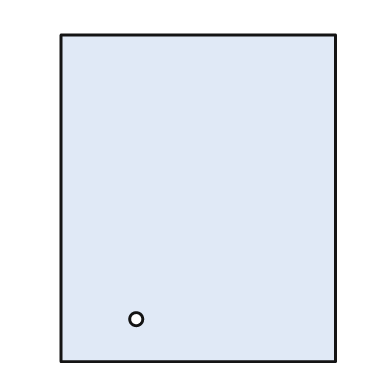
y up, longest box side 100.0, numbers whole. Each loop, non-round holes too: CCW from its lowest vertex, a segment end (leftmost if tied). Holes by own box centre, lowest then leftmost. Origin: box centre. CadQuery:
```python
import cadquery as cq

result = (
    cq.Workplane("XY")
    .moveTo(-42.0, -50.0)
    .lineTo(42.0, -50.0)
    .lineTo(42.0, 50.0)
    .lineTo(-42.0, 50.0)
    .close()
    .moveTo(-19.0, -37.0)
    .circle(2.0)
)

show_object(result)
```